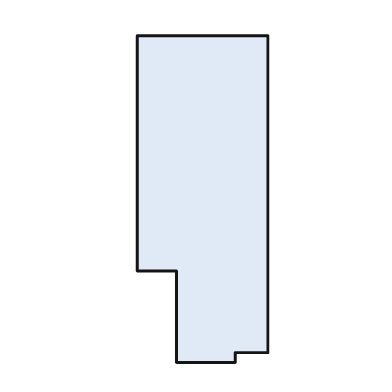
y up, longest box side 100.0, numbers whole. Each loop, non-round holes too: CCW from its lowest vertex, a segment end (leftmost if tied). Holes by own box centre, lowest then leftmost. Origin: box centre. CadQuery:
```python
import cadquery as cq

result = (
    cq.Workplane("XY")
    .moveTo(-8.0, -50.0)
    .lineTo(10.0, -50.0)
    .lineTo(10.0, -47.0)
    .lineTo(20.0, -47.0)
    .lineTo(20.0, 50.0)
    .lineTo(-20.0, 50.0)
    .lineTo(-20.0, -22.0)
    .lineTo(-8.0, -22.0)
    .close()
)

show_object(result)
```